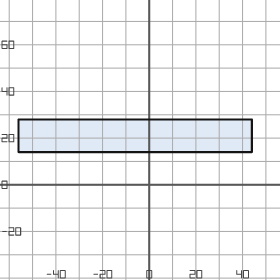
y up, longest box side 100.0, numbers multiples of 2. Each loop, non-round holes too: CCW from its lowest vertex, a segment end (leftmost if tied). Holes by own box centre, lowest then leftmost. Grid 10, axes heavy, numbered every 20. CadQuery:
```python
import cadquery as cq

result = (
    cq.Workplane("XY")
    .moveTo(-56.0, 14.0)
    .lineTo(44.0, 14.0)
    .lineTo(44.0, 28.0)
    .lineTo(-56.0, 28.0)
    .close()
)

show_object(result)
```